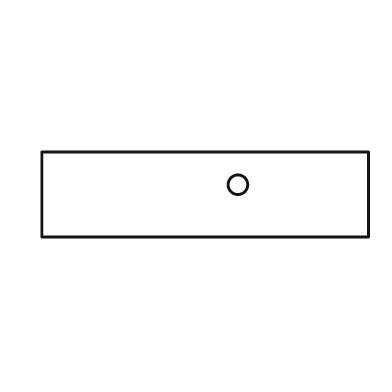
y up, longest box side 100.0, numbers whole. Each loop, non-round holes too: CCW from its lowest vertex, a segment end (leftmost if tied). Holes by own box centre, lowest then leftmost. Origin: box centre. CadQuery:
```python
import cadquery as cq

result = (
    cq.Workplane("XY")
    .moveTo(-50.0, -13.0)
    .lineTo(50.0, -13.0)
    .lineTo(50.0, 13.0)
    .lineTo(-50.0, 13.0)
    .close()
    .moveTo(10.0, 3.0)
    .circle(3.0)
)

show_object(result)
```